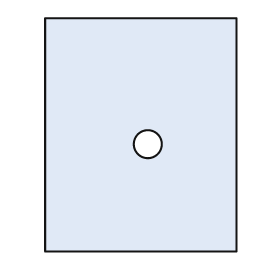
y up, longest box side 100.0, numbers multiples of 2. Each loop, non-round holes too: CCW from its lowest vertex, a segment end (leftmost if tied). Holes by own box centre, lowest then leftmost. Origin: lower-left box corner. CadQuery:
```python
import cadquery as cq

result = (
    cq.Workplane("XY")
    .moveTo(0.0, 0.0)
    .lineTo(82.0, 0.0)
    .lineTo(82.0, 100.0)
    .lineTo(0.0, 100.0)
    .close()
    .moveTo(44.0, 46.0)
    .circle(6.0)
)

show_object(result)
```